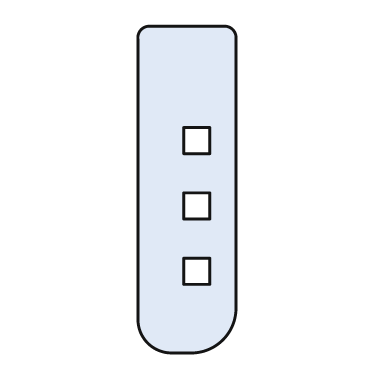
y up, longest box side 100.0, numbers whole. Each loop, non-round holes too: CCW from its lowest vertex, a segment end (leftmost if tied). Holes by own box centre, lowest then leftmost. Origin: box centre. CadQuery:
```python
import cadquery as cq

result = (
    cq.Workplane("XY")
    .moveTo(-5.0, -50.0)
    .lineTo(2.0, -50.0)
    .threePointArc((11.0, -46.0), (15.0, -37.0))
    .lineTo(15.0, 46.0)
    .threePointArc((14.0, 49.0), (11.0, 50.0))
    .lineTo(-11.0, 50.0)
    .threePointArc((-14.0, 49.0), (-15.0, 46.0))
    .lineTo(-15.0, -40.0)
    .threePointArc((-12.0, -47.0), (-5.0, -50.0))
    .close()
    .moveTo(-1.0, -29.0)
    .lineTo(7.0, -29.0)
    .lineTo(7.0, -21.0)
    .lineTo(-1.0, -21.0)
    .close()
    .moveTo(-1.0, -9.0)
    .lineTo(7.0, -9.0)
    .lineTo(7.0, -1.0)
    .lineTo(-1.0, -1.0)
    .close()
    .moveTo(-1.0, 11.0)
    .lineTo(7.0, 11.0)
    .lineTo(7.0, 19.0)
    .lineTo(-1.0, 19.0)
    .close()
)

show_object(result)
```